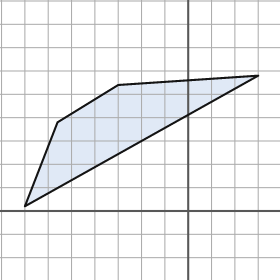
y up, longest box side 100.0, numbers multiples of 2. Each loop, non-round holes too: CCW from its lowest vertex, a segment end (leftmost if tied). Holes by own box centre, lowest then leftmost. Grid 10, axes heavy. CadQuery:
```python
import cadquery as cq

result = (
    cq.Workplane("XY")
    .moveTo(-70.0, 2.0)
    .lineTo(30.0, 58.0)
    .lineTo(-30.0, 54.0)
    .lineTo(-56.0, 38.0)
    .close()
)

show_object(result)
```